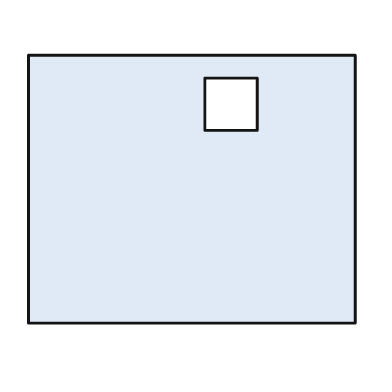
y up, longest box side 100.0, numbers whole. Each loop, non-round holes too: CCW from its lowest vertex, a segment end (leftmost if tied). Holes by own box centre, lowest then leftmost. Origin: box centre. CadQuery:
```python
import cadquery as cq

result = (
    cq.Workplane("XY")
    .moveTo(-50.0, -41.0)
    .lineTo(50.0, -41.0)
    .lineTo(50.0, 41.0)
    .lineTo(-50.0, 41.0)
    .close()
    .moveTo(4.0, 18.0)
    .lineTo(20.0, 18.0)
    .lineTo(20.0, 34.0)
    .lineTo(4.0, 34.0)
    .close()
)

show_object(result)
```